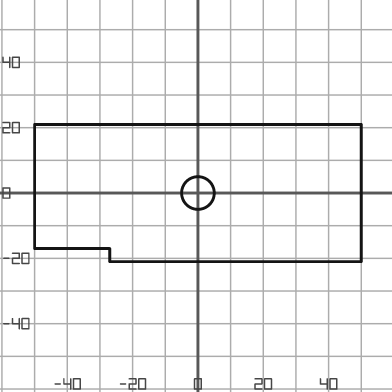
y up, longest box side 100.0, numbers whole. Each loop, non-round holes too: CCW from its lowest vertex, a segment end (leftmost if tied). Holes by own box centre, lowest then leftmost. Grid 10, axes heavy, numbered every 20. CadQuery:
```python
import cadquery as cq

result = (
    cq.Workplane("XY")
    .moveTo(-27.0, -21.0)
    .lineTo(50.0, -21.0)
    .lineTo(50.0, 21.0)
    .lineTo(-50.0, 21.0)
    .lineTo(-50.0, -17.0)
    .lineTo(-27.0, -17.0)
    .close()
    .moveTo(0.0, 0.0)
    .circle(5.0)
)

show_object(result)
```